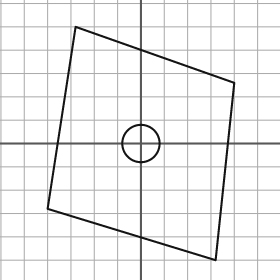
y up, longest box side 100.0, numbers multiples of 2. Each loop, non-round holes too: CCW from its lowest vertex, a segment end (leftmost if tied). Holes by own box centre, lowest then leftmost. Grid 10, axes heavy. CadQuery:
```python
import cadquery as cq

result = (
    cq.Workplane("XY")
    .moveTo(32.0, -50.0)
    .lineTo(40.0, 26.0)
    .lineTo(-28.0, 50.0)
    .lineTo(-40.0, -28.0)
    .close()
    .moveTo(0.0, 0.0)
    .circle(8.0)
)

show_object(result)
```